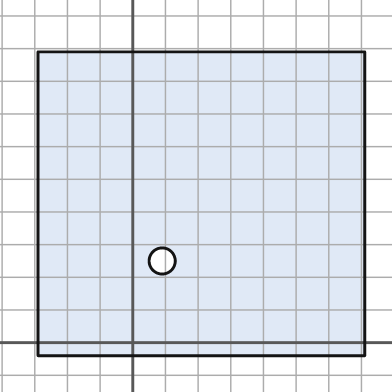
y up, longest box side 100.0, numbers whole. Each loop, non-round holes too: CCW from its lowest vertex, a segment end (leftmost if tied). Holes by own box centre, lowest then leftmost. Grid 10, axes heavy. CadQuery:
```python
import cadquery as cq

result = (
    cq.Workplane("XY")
    .moveTo(-29.0, -4.0)
    .lineTo(71.0, -4.0)
    .lineTo(71.0, 89.0)
    .lineTo(-29.0, 89.0)
    .close()
    .moveTo(9.0, 25.0)
    .circle(4.0)
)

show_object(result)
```